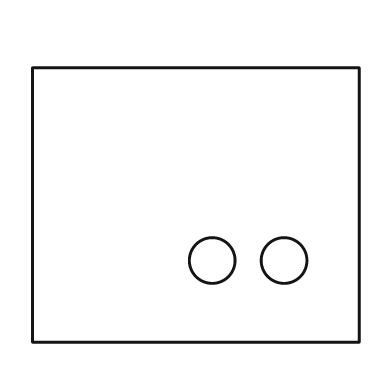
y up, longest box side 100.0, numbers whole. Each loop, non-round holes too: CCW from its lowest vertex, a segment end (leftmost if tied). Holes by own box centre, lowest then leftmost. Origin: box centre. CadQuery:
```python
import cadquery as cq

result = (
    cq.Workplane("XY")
    .moveTo(-50.0, -42.0)
    .lineTo(50.0, -42.0)
    .lineTo(50.0, 42.0)
    .lineTo(-50.0, 42.0)
    .close()
    .moveTo(5.0, -17.0)
    .circle(7.0)
    .moveTo(27.0, -17.0)
    .circle(7.0)
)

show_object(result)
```